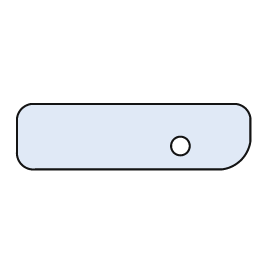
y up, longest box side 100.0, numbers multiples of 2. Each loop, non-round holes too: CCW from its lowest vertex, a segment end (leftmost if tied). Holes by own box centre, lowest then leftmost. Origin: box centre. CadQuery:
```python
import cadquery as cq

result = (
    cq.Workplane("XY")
    .moveTo(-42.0, -14.0)
    .lineTo(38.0, -14.0)
    .threePointArc((46.0, -10.0), (50.0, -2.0))
    .lineTo(50.0, 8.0)
    .threePointArc((48.0, 12.0), (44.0, 14.0))
    .lineTo(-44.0, 14.0)
    .threePointArc((-48.0, 12.0), (-50.0, 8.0))
    .lineTo(-50.0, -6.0)
    .threePointArc((-48.0, -12.0), (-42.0, -14.0))
    .close()
    .moveTo(20.0, -4.0)
    .circle(4.0)
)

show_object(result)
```